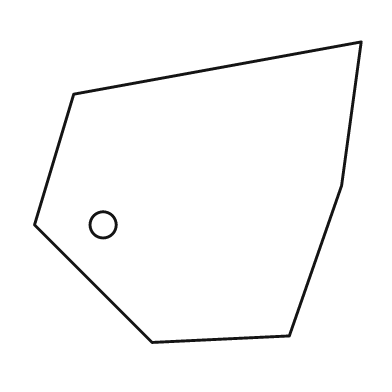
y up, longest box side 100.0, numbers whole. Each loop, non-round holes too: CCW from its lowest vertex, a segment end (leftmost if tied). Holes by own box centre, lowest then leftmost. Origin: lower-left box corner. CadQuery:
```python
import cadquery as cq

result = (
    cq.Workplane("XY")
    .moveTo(36.0, 0.0)
    .lineTo(78.0, 2.0)
    .lineTo(94.0, 48.0)
    .lineTo(100.0, 92.0)
    .lineTo(12.0, 76.0)
    .lineTo(0.0, 36.0)
    .close()
    .moveTo(21.0, 36.0)
    .circle(4.0)
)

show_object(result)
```